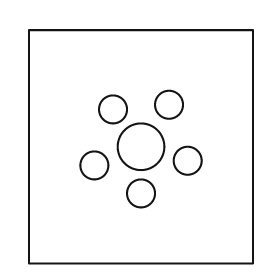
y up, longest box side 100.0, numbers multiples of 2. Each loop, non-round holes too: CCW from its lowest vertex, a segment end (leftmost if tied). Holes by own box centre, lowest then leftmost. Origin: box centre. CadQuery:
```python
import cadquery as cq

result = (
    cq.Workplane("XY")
    .moveTo(-48.0, -50.0)
    .lineTo(48.0, -50.0)
    .lineTo(48.0, 50.0)
    .lineTo(-48.0, 50.0)
    .close()
    .moveTo(0.0, -20.0)
    .circle(6.0)
    .moveTo(-20.0, -8.0)
    .circle(6.0)
    .moveTo(20.0, -6.0)
    .circle(6.0)
    .moveTo(0.0, 0.0)
    .circle(10.0)
    .moveTo(-12.0, 16.0)
    .circle(6.0)
    .moveTo(12.0, 18.0)
    .circle(6.0)
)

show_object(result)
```